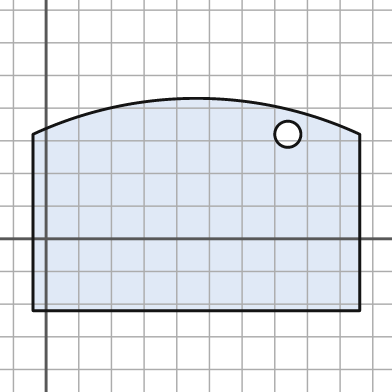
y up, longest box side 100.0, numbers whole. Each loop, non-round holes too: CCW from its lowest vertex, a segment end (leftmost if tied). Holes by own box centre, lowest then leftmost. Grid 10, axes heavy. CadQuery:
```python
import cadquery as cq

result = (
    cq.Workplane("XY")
    .moveTo(-4.0, -22.0)
    .lineTo(96.0, -22.0)
    .lineTo(96.0, 32.0)
    .threePointArc((46.0, 43.0), (-4.0, 32.0))
    .close()
    .moveTo(74.0, 32.0)
    .circle(4.0)
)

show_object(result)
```